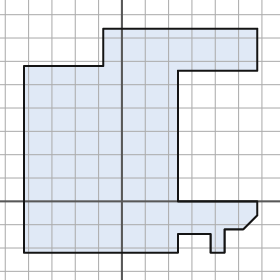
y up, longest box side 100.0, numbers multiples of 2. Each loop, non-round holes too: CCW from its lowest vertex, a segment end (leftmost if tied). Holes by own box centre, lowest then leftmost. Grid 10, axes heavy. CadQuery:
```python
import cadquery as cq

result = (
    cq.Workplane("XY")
    .moveTo(-42.0, -22.0)
    .lineTo(24.0, -22.0)
    .lineTo(24.0, -14.0)
    .lineTo(38.0, -14.0)
    .lineTo(38.0, -22.0)
    .lineTo(44.0, -22.0)
    .lineTo(44.0, -12.0)
    .lineTo(52.0, -12.0)
    .lineTo(58.0, -6.0)
    .lineTo(58.0, 0.0)
    .lineTo(24.0, 0.0)
    .lineTo(24.0, 56.0)
    .lineTo(58.0, 56.0)
    .lineTo(58.0, 74.0)
    .lineTo(-8.0, 74.0)
    .lineTo(-8.0, 58.0)
    .lineTo(-42.0, 58.0)
    .close()
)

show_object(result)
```